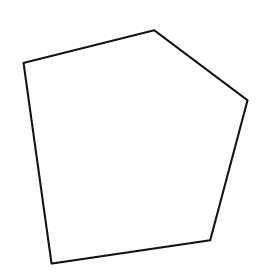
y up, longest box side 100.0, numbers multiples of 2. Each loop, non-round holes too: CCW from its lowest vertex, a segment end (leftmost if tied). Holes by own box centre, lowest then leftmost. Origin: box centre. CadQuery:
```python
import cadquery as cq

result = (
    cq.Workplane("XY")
    .moveTo(-36.0, -50.0)
    .lineTo(32.0, -40.0)
    .lineTo(48.0, 20.0)
    .lineTo(8.0, 50.0)
    .lineTo(-48.0, 36.0)
    .close()
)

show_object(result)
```